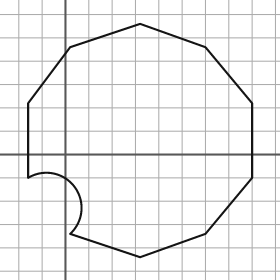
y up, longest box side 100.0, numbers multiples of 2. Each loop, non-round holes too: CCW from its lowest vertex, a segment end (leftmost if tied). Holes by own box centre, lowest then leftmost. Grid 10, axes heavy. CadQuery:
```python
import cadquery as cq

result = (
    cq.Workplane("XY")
    .moveTo(32.0, -44.0)
    .lineTo(60.0, -34.0)
    .lineTo(80.0, -10.0)
    .lineTo(80.0, 22.0)
    .lineTo(60.0, 46.0)
    .lineTo(32.0, 56.0)
    .lineTo(2.0, 46.0)
    .lineTo(-16.0, 22.0)
    .lineTo(-16.0, -10.0)
    .threePointArc((4.0, -14.0), (2.0, -34.0))
    .close()
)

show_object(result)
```